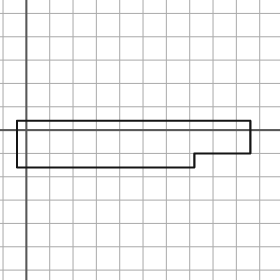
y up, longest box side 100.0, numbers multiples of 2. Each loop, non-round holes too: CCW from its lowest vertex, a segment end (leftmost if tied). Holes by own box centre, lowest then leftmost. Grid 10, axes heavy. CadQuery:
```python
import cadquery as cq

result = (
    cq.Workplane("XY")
    .moveTo(-4.0, -16.0)
    .lineTo(72.0, -16.0)
    .lineTo(72.0, -10.0)
    .lineTo(96.0, -10.0)
    .lineTo(96.0, 4.0)
    .lineTo(-4.0, 4.0)
    .close()
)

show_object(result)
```